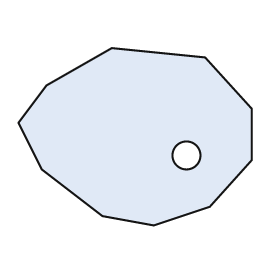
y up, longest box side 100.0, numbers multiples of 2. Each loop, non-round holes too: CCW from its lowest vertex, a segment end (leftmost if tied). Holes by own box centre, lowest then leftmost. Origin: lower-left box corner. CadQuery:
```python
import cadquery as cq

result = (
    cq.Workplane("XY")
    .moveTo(58.0, 0.0)
    .lineTo(82.0, 8.0)
    .lineTo(100.0, 28.0)
    .lineTo(100.0, 50.0)
    .lineTo(80.0, 72.0)
    .lineTo(40.0, 76.0)
    .lineTo(12.0, 60.0)
    .lineTo(0.0, 44.0)
    .lineTo(10.0, 24.0)
    .lineTo(36.0, 4.0)
    .close()
    .moveTo(72.0, 30.0)
    .circle(6.0)
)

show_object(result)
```